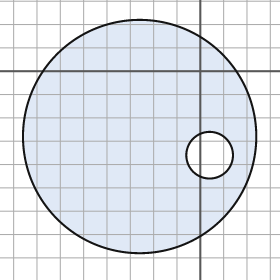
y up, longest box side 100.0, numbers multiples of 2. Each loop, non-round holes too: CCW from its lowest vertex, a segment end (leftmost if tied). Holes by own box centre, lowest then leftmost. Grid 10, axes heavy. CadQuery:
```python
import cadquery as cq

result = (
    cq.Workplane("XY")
    .moveTo(-26.0, -28.0)
    .circle(50.0)
    .moveTo(4.0, -36.0)
    .circle(10.0)
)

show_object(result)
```